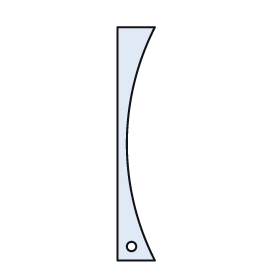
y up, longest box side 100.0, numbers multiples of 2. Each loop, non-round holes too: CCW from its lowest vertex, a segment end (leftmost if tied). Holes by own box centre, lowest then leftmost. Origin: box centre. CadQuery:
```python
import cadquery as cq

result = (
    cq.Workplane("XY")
    .moveTo(-8.0, -50.0)
    .lineTo(8.0, -50.0)
    .threePointArc((-4.0, 0.0), (8.0, 50.0))
    .lineTo(-8.0, 50.0)
    .close()
    .moveTo(-2.0, -44.0)
    .circle(2.0)
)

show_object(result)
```